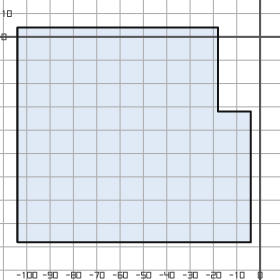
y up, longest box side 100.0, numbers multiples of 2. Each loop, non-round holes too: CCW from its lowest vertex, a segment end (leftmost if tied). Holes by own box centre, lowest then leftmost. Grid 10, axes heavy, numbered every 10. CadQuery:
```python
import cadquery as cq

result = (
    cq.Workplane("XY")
    .moveTo(-104.0, -88.0)
    .lineTo(-4.0, -88.0)
    .lineTo(-4.0, -32.0)
    .lineTo(-18.0, -32.0)
    .lineTo(-18.0, 4.0)
    .lineTo(-104.0, 4.0)
    .close()
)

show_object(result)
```